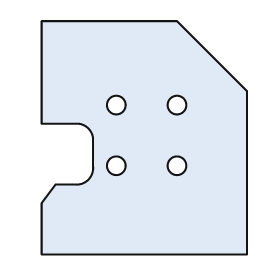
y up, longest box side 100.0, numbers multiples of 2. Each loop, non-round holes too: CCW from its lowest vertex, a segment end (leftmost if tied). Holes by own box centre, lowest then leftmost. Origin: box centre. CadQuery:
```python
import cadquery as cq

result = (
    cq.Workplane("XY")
    .moveTo(-44.0, -50.0)
    .lineTo(44.0, -50.0)
    .lineTo(44.0, 20.0)
    .lineTo(14.0, 50.0)
    .lineTo(-44.0, 50.0)
    .lineTo(-44.0, 6.0)
    .lineTo(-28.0, 6.0)
    .threePointArc((-24.0, 4.0), (-22.0, 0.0))
    .lineTo(-22.0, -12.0)
    .threePointArc((-24.0, -18.0), (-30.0, -20.0))
    .lineTo(-38.0, -20.0)
    .lineTo(-44.0, -28.0)
    .close()
    .moveTo(-12.0, -12.0)
    .circle(4.0)
    .moveTo(14.0, -12.0)
    .circle(4.0)
    .moveTo(-12.0, 14.0)
    .circle(4.0)
    .moveTo(14.0, 14.0)
    .circle(4.0)
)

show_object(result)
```